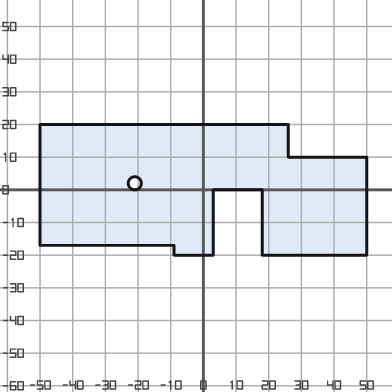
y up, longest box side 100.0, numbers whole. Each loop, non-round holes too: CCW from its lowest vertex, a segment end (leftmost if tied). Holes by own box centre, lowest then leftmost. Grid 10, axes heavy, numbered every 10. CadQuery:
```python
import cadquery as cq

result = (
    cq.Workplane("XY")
    .moveTo(-9.0, -20.0)
    .lineTo(3.0, -20.0)
    .lineTo(3.0, 0.0)
    .lineTo(18.0, 0.0)
    .lineTo(18.0, -20.0)
    .lineTo(50.0, -20.0)
    .lineTo(50.0, 10.0)
    .lineTo(26.0, 10.0)
    .lineTo(26.0, 20.0)
    .lineTo(-50.0, 20.0)
    .lineTo(-50.0, -17.0)
    .lineTo(-9.0, -17.0)
    .close()
    .moveTo(-21.0, 2.0)
    .circle(2.0)
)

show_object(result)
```